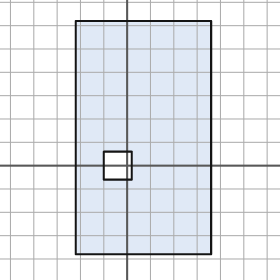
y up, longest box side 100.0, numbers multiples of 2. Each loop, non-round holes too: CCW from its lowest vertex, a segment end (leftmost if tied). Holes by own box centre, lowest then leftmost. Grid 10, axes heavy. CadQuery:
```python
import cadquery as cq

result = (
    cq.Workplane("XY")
    .moveTo(-22.0, -38.0)
    .lineTo(36.0, -38.0)
    .lineTo(36.0, 62.0)
    .lineTo(-22.0, 62.0)
    .close()
    .moveTo(-10.0, -6.0)
    .lineTo(2.0, -6.0)
    .lineTo(2.0, 6.0)
    .lineTo(-10.0, 6.0)
    .close()
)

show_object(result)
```